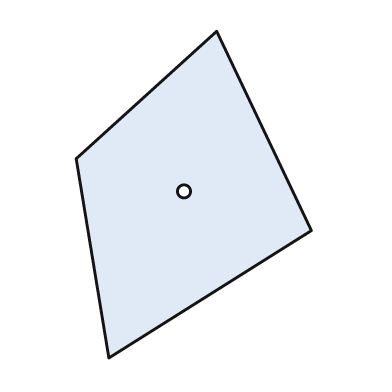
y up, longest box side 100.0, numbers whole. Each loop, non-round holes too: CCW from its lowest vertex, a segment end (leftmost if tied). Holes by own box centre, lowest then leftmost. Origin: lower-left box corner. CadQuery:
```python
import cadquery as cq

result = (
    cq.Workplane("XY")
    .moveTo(10.0, 0.0)
    .lineTo(72.0, 39.0)
    .lineTo(43.0, 100.0)
    .lineTo(0.0, 61.0)
    .close()
    .moveTo(33.0, 51.0)
    .circle(2.0)
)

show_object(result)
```